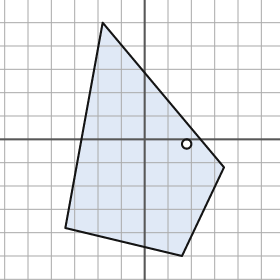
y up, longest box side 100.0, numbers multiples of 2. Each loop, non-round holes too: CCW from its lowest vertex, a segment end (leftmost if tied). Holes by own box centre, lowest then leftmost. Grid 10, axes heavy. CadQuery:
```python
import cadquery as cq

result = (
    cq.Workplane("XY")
    .moveTo(16.0, -50.0)
    .lineTo(34.0, -12.0)
    .lineTo(-18.0, 50.0)
    .lineTo(-34.0, -38.0)
    .close()
    .moveTo(18.0, -2.0)
    .circle(2.0)
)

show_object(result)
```